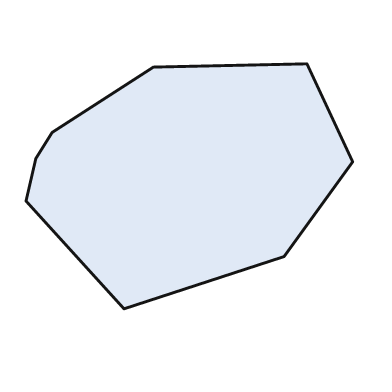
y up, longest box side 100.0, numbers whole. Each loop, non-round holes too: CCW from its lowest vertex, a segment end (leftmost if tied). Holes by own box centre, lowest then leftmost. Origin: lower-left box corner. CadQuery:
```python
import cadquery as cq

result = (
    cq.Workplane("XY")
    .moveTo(30.0, 0.0)
    .lineTo(79.0, 16.0)
    .lineTo(100.0, 45.0)
    .lineTo(86.0, 75.0)
    .lineTo(39.0, 74.0)
    .lineTo(8.0, 54.0)
    .lineTo(3.0, 46.0)
    .lineTo(0.0, 33.0)
    .close()
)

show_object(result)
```